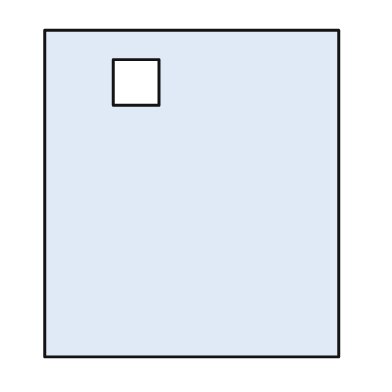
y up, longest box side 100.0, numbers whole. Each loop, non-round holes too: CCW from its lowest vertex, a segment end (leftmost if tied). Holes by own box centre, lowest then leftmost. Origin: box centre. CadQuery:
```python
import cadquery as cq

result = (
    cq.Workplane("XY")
    .moveTo(-45.0, -50.0)
    .lineTo(45.0, -50.0)
    .lineTo(45.0, 50.0)
    .lineTo(-45.0, 50.0)
    .close()
    .moveTo(-24.0, 27.0)
    .lineTo(-10.0, 27.0)
    .lineTo(-10.0, 41.0)
    .lineTo(-24.0, 41.0)
    .close()
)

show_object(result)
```